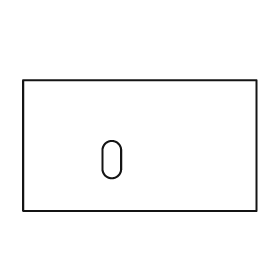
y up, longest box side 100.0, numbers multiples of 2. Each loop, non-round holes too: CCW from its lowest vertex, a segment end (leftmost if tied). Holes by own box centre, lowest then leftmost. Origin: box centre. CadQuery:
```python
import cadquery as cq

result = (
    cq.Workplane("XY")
    .moveTo(-50.0, -28.0)
    .lineTo(50.0, -28.0)
    .lineTo(50.0, 28.0)
    .lineTo(-50.0, 28.0)
    .close()
    .moveTo(-16.0, -10.0)
    .threePointArc((-12.0, -14.0), (-8.0, -10.0))
    .lineTo(-8.0, -2.0)
    .threePointArc((-12.0, 2.0), (-16.0, -2.0))
    .close()
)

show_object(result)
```